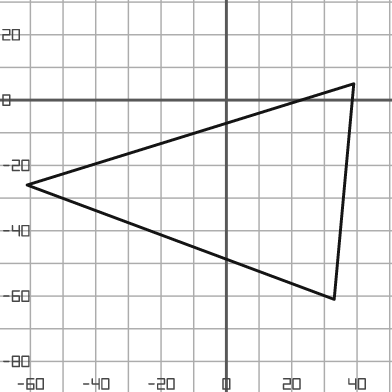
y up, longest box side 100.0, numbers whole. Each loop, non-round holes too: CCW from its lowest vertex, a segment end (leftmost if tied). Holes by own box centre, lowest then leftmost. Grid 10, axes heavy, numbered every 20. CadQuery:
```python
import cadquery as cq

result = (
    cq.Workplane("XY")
    .moveTo(33.0, -61.0)
    .lineTo(39.0, 5.0)
    .lineTo(-61.0, -26.0)
    .close()
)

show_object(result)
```